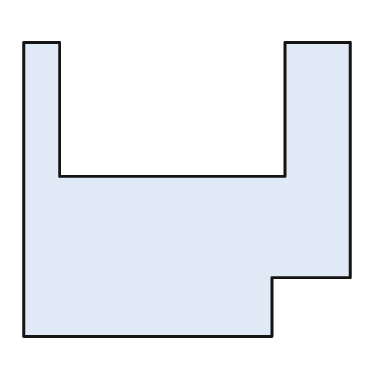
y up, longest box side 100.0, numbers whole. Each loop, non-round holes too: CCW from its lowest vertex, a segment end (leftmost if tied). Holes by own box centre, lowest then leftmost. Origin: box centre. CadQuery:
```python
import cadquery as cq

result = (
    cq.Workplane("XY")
    .moveTo(-50.0, -45.0)
    .lineTo(26.0, -45.0)
    .lineTo(26.0, -27.0)
    .lineTo(50.0, -27.0)
    .lineTo(50.0, 45.0)
    .lineTo(30.0, 45.0)
    .lineTo(30.0, 4.0)
    .lineTo(-39.0, 4.0)
    .lineTo(-39.0, 45.0)
    .lineTo(-50.0, 45.0)
    .close()
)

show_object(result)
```